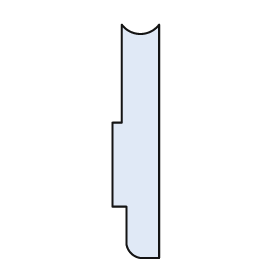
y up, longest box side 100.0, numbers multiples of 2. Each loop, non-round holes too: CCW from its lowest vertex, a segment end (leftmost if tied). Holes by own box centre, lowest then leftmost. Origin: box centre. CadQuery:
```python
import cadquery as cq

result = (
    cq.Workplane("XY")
    .moveTo(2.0, -50.0)
    .lineTo(10.0, -50.0)
    .lineTo(10.0, 50.0)
    .threePointArc((2.0, 46.0), (-6.0, 50.0))
    .lineTo(-6.0, 8.0)
    .lineTo(-10.0, 8.0)
    .lineTo(-10.0, -28.0)
    .lineTo(-4.0, -28.0)
    .lineTo(-4.0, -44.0)
    .threePointArc((-2.0, -48.0), (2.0, -50.0))
    .close()
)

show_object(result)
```